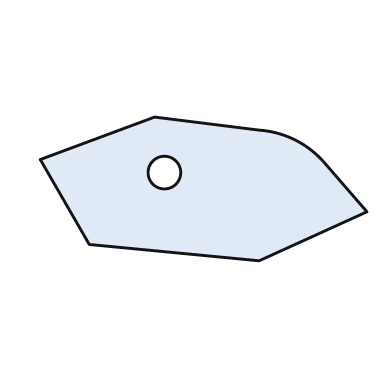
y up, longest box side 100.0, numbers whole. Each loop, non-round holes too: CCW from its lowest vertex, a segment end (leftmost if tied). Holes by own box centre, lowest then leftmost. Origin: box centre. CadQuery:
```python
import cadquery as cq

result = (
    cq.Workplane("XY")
    .moveTo(17.0, -22.0)
    .lineTo(50.0, -7.0)
    .lineTo(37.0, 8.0)
    .threePointArc((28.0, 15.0), (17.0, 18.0))
    .lineTo(-15.0, 22.0)
    .lineTo(-50.0, 9.0)
    .lineTo(-35.0, -17.0)
    .close()
    .moveTo(-12.0, 5.0)
    .circle(5.0)
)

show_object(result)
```